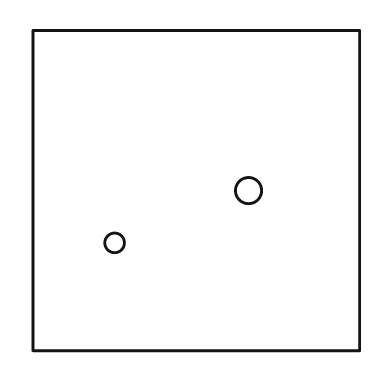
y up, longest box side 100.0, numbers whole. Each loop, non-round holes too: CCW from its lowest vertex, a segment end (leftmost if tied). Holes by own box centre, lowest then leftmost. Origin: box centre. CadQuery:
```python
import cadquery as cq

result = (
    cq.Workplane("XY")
    .moveTo(-50.0, -49.0)
    .lineTo(50.0, -49.0)
    .lineTo(50.0, 49.0)
    .lineTo(-50.0, 49.0)
    .close()
    .moveTo(-25.0, -16.0)
    .circle(3.0)
    .moveTo(16.0, 0.0)
    .circle(4.0)
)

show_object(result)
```